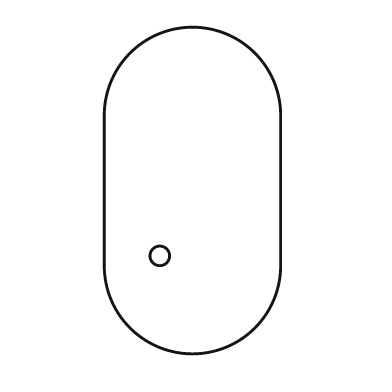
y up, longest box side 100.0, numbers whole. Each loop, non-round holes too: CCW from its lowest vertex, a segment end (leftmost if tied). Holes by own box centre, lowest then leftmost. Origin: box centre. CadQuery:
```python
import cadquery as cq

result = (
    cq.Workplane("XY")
    .moveTo(-27.0, -23.0)
    .threePointArc((0.0, -50.0), (27.0, -23.0))
    .lineTo(27.0, 23.0)
    .threePointArc((0.0, 50.0), (-27.0, 23.0))
    .close()
    .moveTo(-10.0, -20.0)
    .circle(3.0)
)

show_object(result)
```